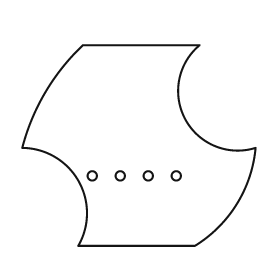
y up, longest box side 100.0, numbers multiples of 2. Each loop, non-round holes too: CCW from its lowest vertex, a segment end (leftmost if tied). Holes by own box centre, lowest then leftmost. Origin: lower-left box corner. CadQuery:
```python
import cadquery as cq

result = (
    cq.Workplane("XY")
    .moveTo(24.0, 0.0)
    .lineTo(74.0, 0.0)
    .threePointArc((92.0, 18.0), (100.0, 42.0))
    .threePointArc((70.0, 54.0), (76.0, 86.0))
    .lineTo(26.0, 86.0)
    .threePointArc((10.0, 66.0), (0.0, 42.0))
    .threePointArc((24.0, 28.0), (24.0, 0.0))
    .close()
    .moveTo(30.0, 30.0)
    .circle(2.0)
    .moveTo(42.0, 30.0)
    .circle(2.0)
    .moveTo(54.0, 30.0)
    .circle(2.0)
    .moveTo(66.0, 30.0)
    .circle(2.0)
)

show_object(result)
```